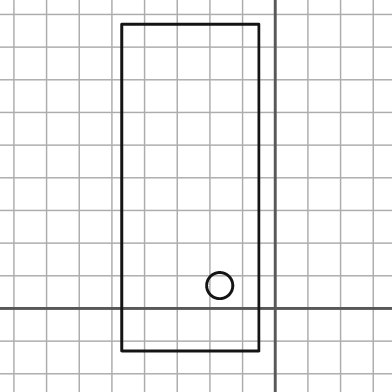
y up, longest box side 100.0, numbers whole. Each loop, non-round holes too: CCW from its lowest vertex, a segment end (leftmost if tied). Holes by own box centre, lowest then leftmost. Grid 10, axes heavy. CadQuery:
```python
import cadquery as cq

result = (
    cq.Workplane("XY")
    .moveTo(-47.0, -13.0)
    .lineTo(-5.0, -13.0)
    .lineTo(-5.0, 87.0)
    .lineTo(-47.0, 87.0)
    .close()
    .moveTo(-17.0, 7.0)
    .circle(4.0)
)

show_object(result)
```